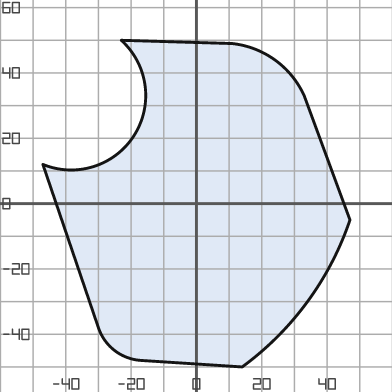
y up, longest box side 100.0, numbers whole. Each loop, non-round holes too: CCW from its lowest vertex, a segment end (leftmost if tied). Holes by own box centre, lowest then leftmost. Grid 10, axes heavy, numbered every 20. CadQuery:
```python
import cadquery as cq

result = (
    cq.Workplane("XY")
    .moveTo(14.0, -50.0)
    .threePointArc((34.0, -30.0), (47.0, -5.0))
    .lineTo(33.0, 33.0)
    .threePointArc((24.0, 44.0), (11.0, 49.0))
    .lineTo(-23.0, 50.0)
    .threePointArc((-19.0, 21.0), (-47.0, 12.0))
    .lineTo(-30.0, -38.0)
    .threePointArc((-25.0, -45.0), (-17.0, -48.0))
    .close()
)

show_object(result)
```